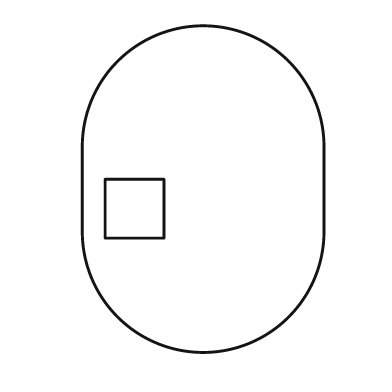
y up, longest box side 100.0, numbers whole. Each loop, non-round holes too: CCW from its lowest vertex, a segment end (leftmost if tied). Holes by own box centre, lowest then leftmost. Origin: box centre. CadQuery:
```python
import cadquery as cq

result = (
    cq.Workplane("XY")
    .moveTo(-37.0, -13.0)
    .threePointArc((0.0, -50.0), (37.0, -13.0))
    .lineTo(37.0, 13.0)
    .threePointArc((0.0, 50.0), (-37.0, 13.0))
    .close()
    .moveTo(-30.0, -15.0)
    .lineTo(-12.0, -15.0)
    .lineTo(-12.0, 3.0)
    .lineTo(-30.0, 3.0)
    .close()
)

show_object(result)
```